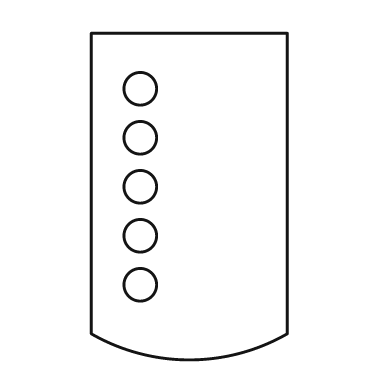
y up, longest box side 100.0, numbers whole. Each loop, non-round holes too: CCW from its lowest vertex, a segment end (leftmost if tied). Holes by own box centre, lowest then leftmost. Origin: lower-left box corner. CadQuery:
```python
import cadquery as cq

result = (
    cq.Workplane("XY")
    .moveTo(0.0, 8.0)
    .threePointArc((30.0, 0.0), (60.0, 8.0))
    .lineTo(60.0, 100.0)
    .lineTo(0.0, 100.0)
    .close()
    .moveTo(15.0, 23.0)
    .circle(5.0)
    .moveTo(15.0, 38.0)
    .circle(5.0)
    .moveTo(15.0, 53.0)
    .circle(5.0)
    .moveTo(15.0, 68.0)
    .circle(5.0)
    .moveTo(15.0, 83.0)
    .circle(5.0)
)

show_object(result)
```